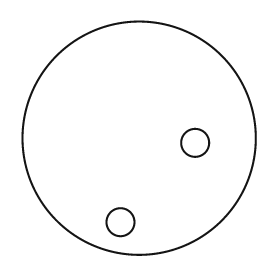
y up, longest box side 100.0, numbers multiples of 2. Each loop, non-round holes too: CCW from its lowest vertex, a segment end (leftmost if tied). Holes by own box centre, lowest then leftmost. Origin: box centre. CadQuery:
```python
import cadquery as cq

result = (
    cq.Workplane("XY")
    .moveTo(0.0, 0.0)
    .circle(50.0)
    .moveTo(-8.0, -36.0)
    .circle(6.0)
    .moveTo(24.0, -2.0)
    .circle(6.0)
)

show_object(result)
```